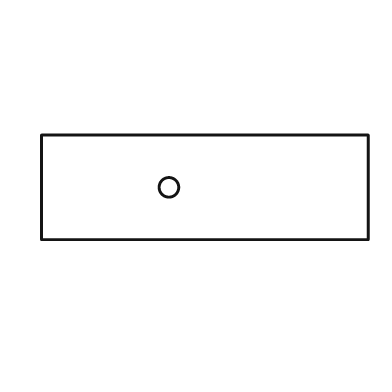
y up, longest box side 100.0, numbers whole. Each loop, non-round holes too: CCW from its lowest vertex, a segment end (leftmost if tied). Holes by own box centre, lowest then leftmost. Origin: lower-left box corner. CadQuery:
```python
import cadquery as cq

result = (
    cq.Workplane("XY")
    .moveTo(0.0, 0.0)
    .lineTo(100.0, 0.0)
    .lineTo(100.0, 32.0)
    .lineTo(0.0, 32.0)
    .close()
    .moveTo(39.0, 16.0)
    .circle(3.0)
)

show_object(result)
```